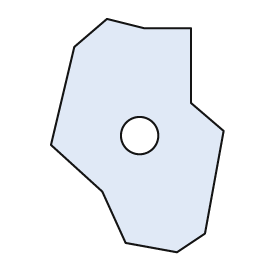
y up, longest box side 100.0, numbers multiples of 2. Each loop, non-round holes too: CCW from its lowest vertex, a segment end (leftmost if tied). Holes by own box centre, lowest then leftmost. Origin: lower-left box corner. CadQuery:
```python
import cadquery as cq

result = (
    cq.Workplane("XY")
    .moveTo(54.0, 0.0)
    .lineTo(66.0, 8.0)
    .lineTo(74.0, 52.0)
    .lineTo(60.0, 64.0)
    .lineTo(60.0, 96.0)
    .lineTo(40.0, 96.0)
    .lineTo(24.0, 100.0)
    .lineTo(10.0, 88.0)
    .lineTo(0.0, 46.0)
    .lineTo(22.0, 26.0)
    .lineTo(32.0, 4.0)
    .close()
    .moveTo(38.0, 50.0)
    .circle(8.0)
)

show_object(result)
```